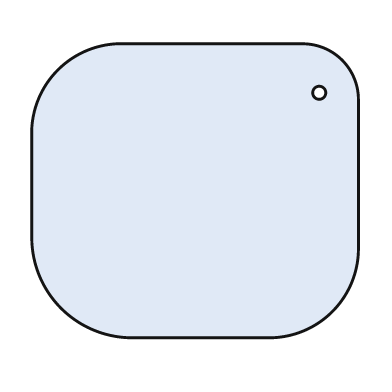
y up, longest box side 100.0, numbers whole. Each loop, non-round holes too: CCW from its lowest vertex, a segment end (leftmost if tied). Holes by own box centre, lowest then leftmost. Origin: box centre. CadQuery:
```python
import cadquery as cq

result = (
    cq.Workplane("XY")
    .moveTo(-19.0, -45.0)
    .lineTo(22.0, -45.0)
    .threePointArc((42.0, -37.0), (50.0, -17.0))
    .lineTo(50.0, 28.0)
    .threePointArc((45.0, 40.0), (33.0, 45.0))
    .lineTo(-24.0, 45.0)
    .threePointArc((-42.0, 37.0), (-50.0, 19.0))
    .lineTo(-50.0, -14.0)
    .threePointArc((-41.0, -36.0), (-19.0, -45.0))
    .close()
    .moveTo(38.0, 30.0)
    .circle(2.0)
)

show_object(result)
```